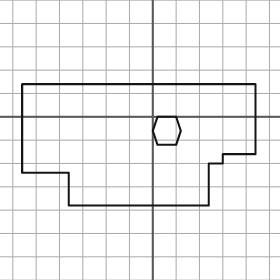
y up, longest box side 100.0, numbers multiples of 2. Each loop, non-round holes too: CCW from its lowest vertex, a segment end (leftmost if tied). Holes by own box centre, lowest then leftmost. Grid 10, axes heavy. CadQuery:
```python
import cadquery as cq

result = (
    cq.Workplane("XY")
    .moveTo(-36.0, -38.0)
    .lineTo(24.0, -38.0)
    .lineTo(24.0, -20.0)
    .lineTo(30.0, -20.0)
    .lineTo(30.0, -16.0)
    .lineTo(44.0, -16.0)
    .lineTo(44.0, 14.0)
    .lineTo(-56.0, 14.0)
    .lineTo(-56.0, -24.0)
    .lineTo(-36.0, -24.0)
    .close()
    .moveTo(2.0, -12.0)
    .lineTo(10.0, -12.0)
    .lineTo(12.0, -6.0)
    .lineTo(10.0, 0.0)
    .lineTo(2.0, 0.0)
    .lineTo(0.0, -6.0)
    .close()
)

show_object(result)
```